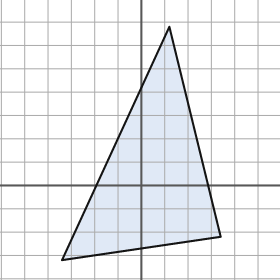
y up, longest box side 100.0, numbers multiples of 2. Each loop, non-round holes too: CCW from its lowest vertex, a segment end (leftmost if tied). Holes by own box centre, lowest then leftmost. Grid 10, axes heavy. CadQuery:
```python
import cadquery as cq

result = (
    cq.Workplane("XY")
    .moveTo(-34.0, -32.0)
    .lineTo(34.0, -22.0)
    .lineTo(12.0, 68.0)
    .close()
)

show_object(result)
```